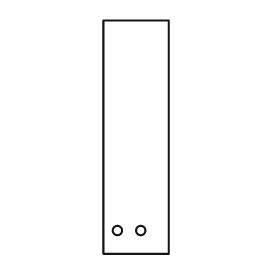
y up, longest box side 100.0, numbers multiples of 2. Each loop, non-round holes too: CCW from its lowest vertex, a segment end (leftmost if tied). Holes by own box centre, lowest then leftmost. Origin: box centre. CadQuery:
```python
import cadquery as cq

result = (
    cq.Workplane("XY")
    .moveTo(-14.0, -50.0)
    .lineTo(14.0, -50.0)
    .lineTo(14.0, 50.0)
    .lineTo(-14.0, 50.0)
    .close()
    .moveTo(-8.0, -40.0)
    .circle(2.0)
    .moveTo(2.0, -40.0)
    .circle(2.0)
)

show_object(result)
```